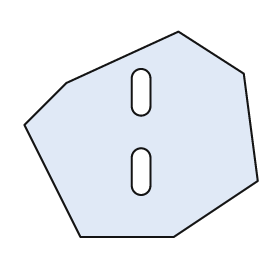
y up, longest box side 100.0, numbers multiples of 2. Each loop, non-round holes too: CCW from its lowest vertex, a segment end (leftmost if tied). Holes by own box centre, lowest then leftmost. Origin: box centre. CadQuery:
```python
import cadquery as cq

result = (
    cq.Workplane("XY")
    .moveTo(-26.0, -44.0)
    .lineTo(14.0, -44.0)
    .lineTo(50.0, -20.0)
    .lineTo(44.0, 26.0)
    .lineTo(16.0, 44.0)
    .lineTo(-32.0, 22.0)
    .lineTo(-50.0, 4.0)
    .close()
    .moveTo(-4.0, -22.0)
    .threePointArc((0.0, -26.0), (4.0, -22.0))
    .lineTo(4.0, -10.0)
    .threePointArc((0.0, -6.0), (-4.0, -10.0))
    .close()
    .moveTo(-4.0, 12.0)
    .threePointArc((0.0, 8.0), (4.0, 12.0))
    .lineTo(4.0, 24.0)
    .threePointArc((0.0, 28.0), (-4.0, 24.0))
    .close()
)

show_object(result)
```